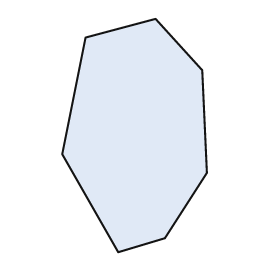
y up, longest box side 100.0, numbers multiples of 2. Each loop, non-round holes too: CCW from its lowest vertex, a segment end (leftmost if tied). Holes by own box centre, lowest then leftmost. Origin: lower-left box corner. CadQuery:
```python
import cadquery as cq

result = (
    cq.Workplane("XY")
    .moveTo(24.0, 0.0)
    .lineTo(44.0, 6.0)
    .lineTo(62.0, 34.0)
    .lineTo(60.0, 78.0)
    .lineTo(40.0, 100.0)
    .lineTo(10.0, 92.0)
    .lineTo(0.0, 42.0)
    .close()
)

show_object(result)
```